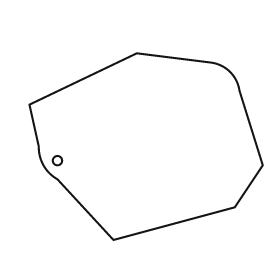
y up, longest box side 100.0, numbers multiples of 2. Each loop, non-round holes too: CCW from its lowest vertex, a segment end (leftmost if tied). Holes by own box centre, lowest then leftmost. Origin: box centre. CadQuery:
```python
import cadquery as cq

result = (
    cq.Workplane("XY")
    .moveTo(-14.0, -40.0)
    .lineTo(38.0, -26.0)
    .lineTo(50.0, -8.0)
    .lineTo(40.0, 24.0)
    .threePointArc((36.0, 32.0), (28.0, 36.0))
    .lineTo(-4.0, 40.0)
    .lineTo(-50.0, 18.0)
    .lineTo(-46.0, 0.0)
    .threePointArc((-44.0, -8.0), (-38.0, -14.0))
    .close()
    .moveTo(-38.0, -6.0)
    .circle(2.0)
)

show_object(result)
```